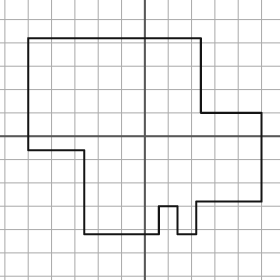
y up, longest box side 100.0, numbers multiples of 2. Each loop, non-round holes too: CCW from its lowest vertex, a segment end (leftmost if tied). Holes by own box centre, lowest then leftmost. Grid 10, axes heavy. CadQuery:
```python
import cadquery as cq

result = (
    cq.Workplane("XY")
    .moveTo(-26.0, -42.0)
    .lineTo(6.0, -42.0)
    .lineTo(6.0, -30.0)
    .lineTo(14.0, -30.0)
    .lineTo(14.0, -42.0)
    .lineTo(22.0, -42.0)
    .lineTo(22.0, -28.0)
    .lineTo(50.0, -28.0)
    .lineTo(50.0, 10.0)
    .lineTo(24.0, 10.0)
    .lineTo(24.0, 42.0)
    .lineTo(-50.0, 42.0)
    .lineTo(-50.0, -6.0)
    .lineTo(-26.0, -6.0)
    .close()
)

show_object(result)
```